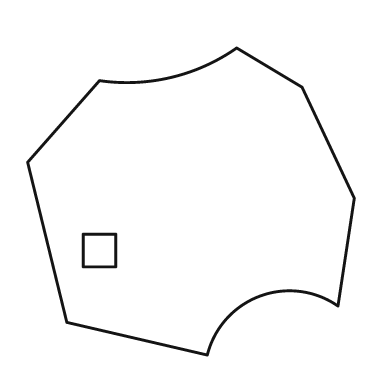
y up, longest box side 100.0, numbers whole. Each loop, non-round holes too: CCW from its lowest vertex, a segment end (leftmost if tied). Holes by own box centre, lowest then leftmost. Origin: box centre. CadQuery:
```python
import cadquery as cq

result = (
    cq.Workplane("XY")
    .moveTo(5.0, -47.0)
    .threePointArc((21.0, -29.0), (45.0, -32.0))
    .lineTo(50.0, 1.0)
    .lineTo(34.0, 35.0)
    .lineTo(14.0, 47.0)
    .threePointArc((-6.0, 38.0), (-28.0, 37.0))
    .lineTo(-50.0, 12.0)
    .lineTo(-38.0, -37.0)
    .close()
    .moveTo(-33.0, -20.0)
    .lineTo(-23.0, -20.0)
    .lineTo(-23.0, -10.0)
    .lineTo(-33.0, -10.0)
    .close()
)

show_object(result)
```